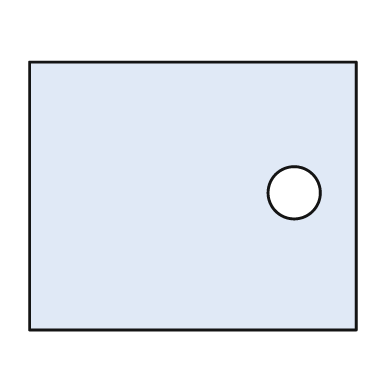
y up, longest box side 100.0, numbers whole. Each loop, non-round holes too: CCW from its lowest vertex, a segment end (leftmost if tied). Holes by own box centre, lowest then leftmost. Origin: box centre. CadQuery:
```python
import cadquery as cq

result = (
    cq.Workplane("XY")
    .moveTo(-50.0, -41.0)
    .lineTo(50.0, -41.0)
    .lineTo(50.0, 41.0)
    .lineTo(-50.0, 41.0)
    .close()
    .moveTo(31.0, 1.0)
    .circle(8.0)
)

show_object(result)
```